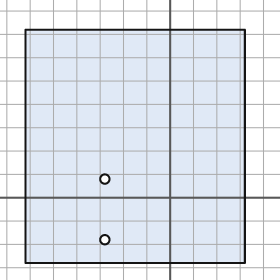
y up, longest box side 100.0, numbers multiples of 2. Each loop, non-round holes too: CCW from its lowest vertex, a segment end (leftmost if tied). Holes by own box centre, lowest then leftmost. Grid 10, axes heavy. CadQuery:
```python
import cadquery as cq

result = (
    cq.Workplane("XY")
    .moveTo(-62.0, -28.0)
    .lineTo(32.0, -28.0)
    .lineTo(32.0, 72.0)
    .lineTo(-62.0, 72.0)
    .close()
    .moveTo(-28.0, -18.0)
    .circle(2.0)
    .moveTo(-28.0, 8.0)
    .circle(2.0)
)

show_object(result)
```